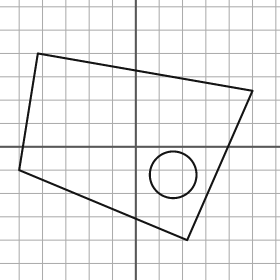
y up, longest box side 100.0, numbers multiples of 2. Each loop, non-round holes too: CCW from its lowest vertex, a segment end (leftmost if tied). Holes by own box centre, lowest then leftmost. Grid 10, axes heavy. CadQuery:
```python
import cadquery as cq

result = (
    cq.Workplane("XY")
    .moveTo(22.0, -40.0)
    .lineTo(50.0, 24.0)
    .lineTo(-42.0, 40.0)
    .lineTo(-50.0, -10.0)
    .close()
    .moveTo(16.0, -12.0)
    .circle(10.0)
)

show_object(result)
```